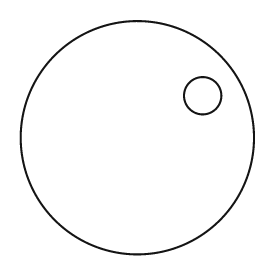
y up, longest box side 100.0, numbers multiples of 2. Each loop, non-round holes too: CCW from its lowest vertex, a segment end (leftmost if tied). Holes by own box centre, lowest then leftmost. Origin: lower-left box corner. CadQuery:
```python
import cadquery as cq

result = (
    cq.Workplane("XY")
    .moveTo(50.0, 50.0)
    .circle(50.0)
    .moveTo(78.0, 68.0)
    .circle(8.0)
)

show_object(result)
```